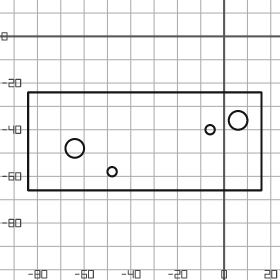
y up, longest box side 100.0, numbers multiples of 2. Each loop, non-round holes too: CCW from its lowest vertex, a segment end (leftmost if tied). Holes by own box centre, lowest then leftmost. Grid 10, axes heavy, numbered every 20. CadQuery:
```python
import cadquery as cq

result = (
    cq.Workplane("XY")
    .moveTo(-84.0, -66.0)
    .lineTo(16.0, -66.0)
    .lineTo(16.0, -24.0)
    .lineTo(-84.0, -24.0)
    .close()
    .moveTo(-48.0, -58.0)
    .circle(2.0)
    .moveTo(-64.0, -48.0)
    .circle(4.0)
    .moveTo(-6.0, -40.0)
    .circle(2.0)
    .moveTo(6.0, -36.0)
    .circle(4.0)
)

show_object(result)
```